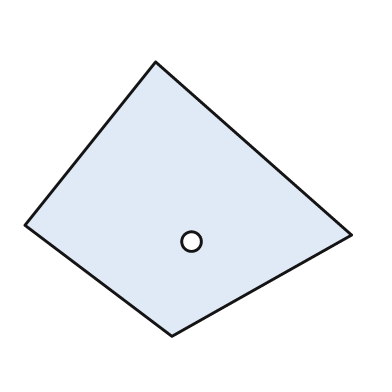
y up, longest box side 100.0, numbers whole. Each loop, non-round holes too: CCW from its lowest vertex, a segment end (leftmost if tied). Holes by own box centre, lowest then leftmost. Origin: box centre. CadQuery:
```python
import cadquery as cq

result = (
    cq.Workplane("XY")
    .moveTo(-5.0, -42.0)
    .lineTo(50.0, -11.0)
    .lineTo(-10.0, 42.0)
    .lineTo(-50.0, -8.0)
    .close()
    .moveTo(1.0, -13.0)
    .circle(3.0)
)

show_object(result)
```